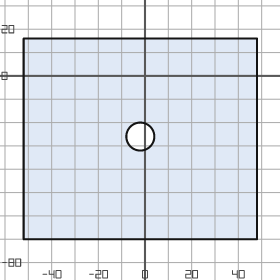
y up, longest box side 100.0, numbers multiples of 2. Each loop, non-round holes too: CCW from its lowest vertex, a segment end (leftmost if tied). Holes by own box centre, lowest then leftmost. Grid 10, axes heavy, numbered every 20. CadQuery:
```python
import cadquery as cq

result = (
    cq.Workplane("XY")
    .moveTo(-52.0, -70.0)
    .lineTo(48.0, -70.0)
    .lineTo(48.0, 16.0)
    .lineTo(-52.0, 16.0)
    .close()
    .moveTo(-2.0, -26.0)
    .circle(6.0)
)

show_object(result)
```